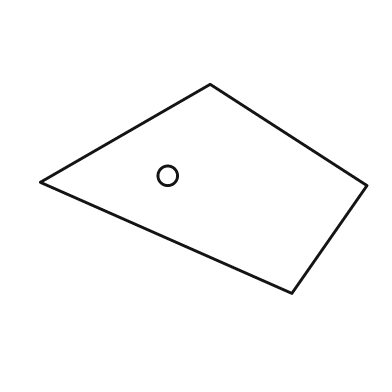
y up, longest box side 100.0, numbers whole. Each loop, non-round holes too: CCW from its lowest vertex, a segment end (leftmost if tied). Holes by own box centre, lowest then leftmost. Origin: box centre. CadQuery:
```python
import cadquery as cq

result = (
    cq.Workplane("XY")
    .moveTo(27.0, -32.0)
    .lineTo(50.0, 1.0)
    .lineTo(2.0, 32.0)
    .lineTo(-50.0, 2.0)
    .close()
    .moveTo(-11.0, 4.0)
    .circle(3.0)
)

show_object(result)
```